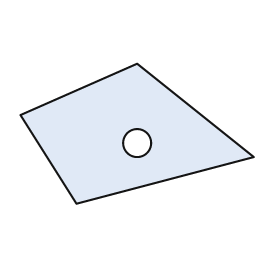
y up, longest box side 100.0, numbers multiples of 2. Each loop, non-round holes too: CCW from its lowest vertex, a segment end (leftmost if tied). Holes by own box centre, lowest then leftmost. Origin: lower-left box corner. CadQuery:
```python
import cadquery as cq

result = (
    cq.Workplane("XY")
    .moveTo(24.0, 0.0)
    .lineTo(100.0, 20.0)
    .lineTo(50.0, 60.0)
    .lineTo(0.0, 38.0)
    .close()
    .moveTo(50.0, 26.0)
    .circle(6.0)
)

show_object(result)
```